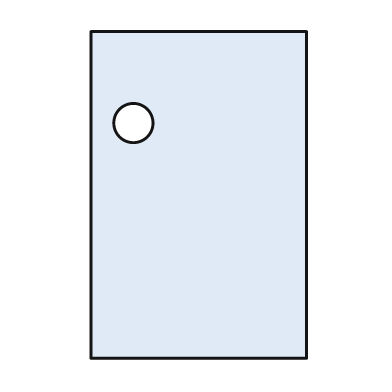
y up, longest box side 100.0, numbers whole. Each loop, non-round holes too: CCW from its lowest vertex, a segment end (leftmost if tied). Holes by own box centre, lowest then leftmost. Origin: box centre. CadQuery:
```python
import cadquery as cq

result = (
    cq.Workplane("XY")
    .moveTo(-33.0, -50.0)
    .lineTo(33.0, -50.0)
    .lineTo(33.0, 50.0)
    .lineTo(-33.0, 50.0)
    .close()
    .moveTo(-20.0, 22.0)
    .circle(6.0)
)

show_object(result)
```